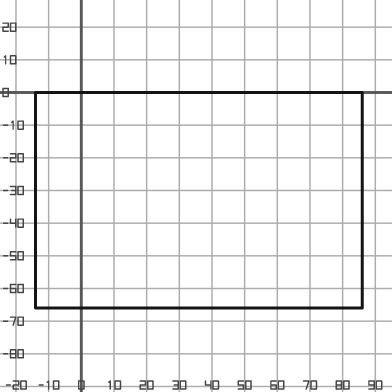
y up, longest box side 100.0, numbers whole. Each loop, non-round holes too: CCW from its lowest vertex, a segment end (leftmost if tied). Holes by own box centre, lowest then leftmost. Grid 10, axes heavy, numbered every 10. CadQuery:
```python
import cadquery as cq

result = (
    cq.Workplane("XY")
    .moveTo(-14.0, -66.0)
    .lineTo(86.0, -66.0)
    .lineTo(86.0, 0.0)
    .lineTo(-14.0, 0.0)
    .close()
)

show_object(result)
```